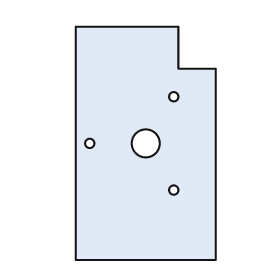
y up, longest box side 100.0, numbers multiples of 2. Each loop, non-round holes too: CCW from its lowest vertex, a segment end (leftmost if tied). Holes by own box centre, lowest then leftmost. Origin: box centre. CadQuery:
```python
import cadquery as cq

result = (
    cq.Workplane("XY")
    .moveTo(-30.0, -50.0)
    .lineTo(30.0, -50.0)
    .lineTo(30.0, 32.0)
    .lineTo(14.0, 32.0)
    .lineTo(14.0, 50.0)
    .lineTo(-30.0, 50.0)
    .close()
    .moveTo(12.0, -20.0)
    .circle(2.0)
    .moveTo(-24.0, 0.0)
    .circle(2.0)
    .moveTo(0.0, 0.0)
    .circle(6.0)
    .moveTo(12.0, 20.0)
    .circle(2.0)
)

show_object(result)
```